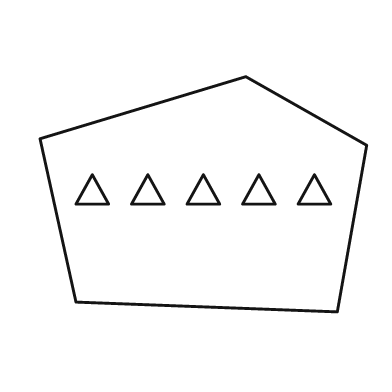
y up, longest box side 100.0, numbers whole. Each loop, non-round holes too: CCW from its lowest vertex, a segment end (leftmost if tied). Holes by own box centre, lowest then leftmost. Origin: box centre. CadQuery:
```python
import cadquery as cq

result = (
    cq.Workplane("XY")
    .moveTo(41.0, -36.0)
    .lineTo(50.0, 15.0)
    .lineTo(13.0, 36.0)
    .lineTo(-50.0, 17.0)
    .lineTo(-39.0, -33.0)
    .close()
    .moveTo(-39.0, -3.0)
    .lineTo(-29.0, -3.0)
    .lineTo(-34.0, 6.0)
    .close()
    .moveTo(-22.0, -3.0)
    .lineTo(-12.0, -3.0)
    .lineTo(-17.0, 6.0)
    .close()
    .moveTo(-5.0, -3.0)
    .lineTo(5.0, -3.0)
    .lineTo(0.0, 6.0)
    .close()
    .moveTo(12.0, -3.0)
    .lineTo(22.0, -3.0)
    .lineTo(17.0, 6.0)
    .close()
    .moveTo(29.0, -3.0)
    .lineTo(39.0, -3.0)
    .lineTo(34.0, 6.0)
    .close()
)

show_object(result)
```